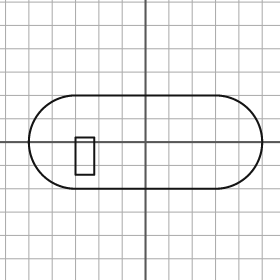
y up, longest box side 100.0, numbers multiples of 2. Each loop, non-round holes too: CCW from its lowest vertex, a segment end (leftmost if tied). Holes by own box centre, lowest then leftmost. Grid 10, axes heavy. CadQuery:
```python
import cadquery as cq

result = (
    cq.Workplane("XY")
    .moveTo(-30.0, -20.0)
    .lineTo(30.0, -20.0)
    .threePointArc((50.0, 0.0), (30.0, 20.0))
    .lineTo(-30.0, 20.0)
    .threePointArc((-50.0, 0.0), (-30.0, -20.0))
    .close()
    .moveTo(-30.0, -14.0)
    .lineTo(-22.0, -14.0)
    .lineTo(-22.0, 2.0)
    .lineTo(-30.0, 2.0)
    .close()
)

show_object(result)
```